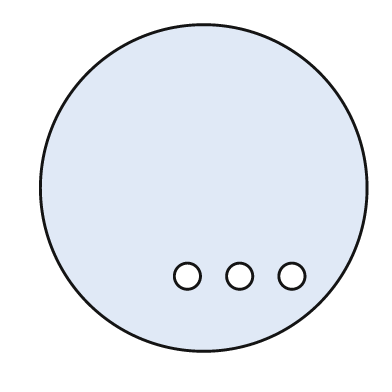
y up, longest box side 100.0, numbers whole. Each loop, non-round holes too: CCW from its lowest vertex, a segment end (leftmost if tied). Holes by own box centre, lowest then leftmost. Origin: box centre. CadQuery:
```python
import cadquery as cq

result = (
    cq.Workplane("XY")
    .moveTo(0.0, 0.0)
    .circle(50.0)
    .moveTo(-5.0, -27.0)
    .circle(4.0)
    .moveTo(11.0, -27.0)
    .circle(4.0)
    .moveTo(27.0, -27.0)
    .circle(4.0)
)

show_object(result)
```